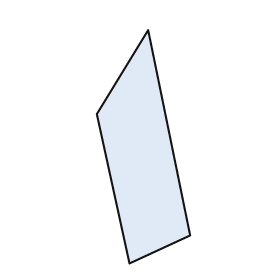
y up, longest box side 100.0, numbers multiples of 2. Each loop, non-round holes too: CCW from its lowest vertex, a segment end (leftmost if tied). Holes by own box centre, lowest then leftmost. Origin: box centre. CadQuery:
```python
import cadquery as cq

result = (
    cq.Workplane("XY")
    .moveTo(-6.0, -50.0)
    .lineTo(20.0, -38.0)
    .lineTo(2.0, 50.0)
    .lineTo(-20.0, 14.0)
    .close()
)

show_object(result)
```